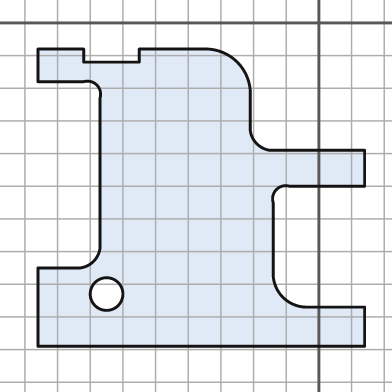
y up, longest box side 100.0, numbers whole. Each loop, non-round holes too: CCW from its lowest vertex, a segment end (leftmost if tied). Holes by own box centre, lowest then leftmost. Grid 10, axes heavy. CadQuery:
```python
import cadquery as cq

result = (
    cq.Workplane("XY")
    .moveTo(-86.0, -99.0)
    .lineTo(14.0, -99.0)
    .lineTo(14.0, -87.0)
    .lineTo(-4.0, -87.0)
    .threePointArc((-11.0, -84.0), (-14.0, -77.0))
    .lineTo(-14.0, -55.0)
    .threePointArc((-13.0, -51.0), (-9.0, -50.0))
    .lineTo(14.0, -50.0)
    .lineTo(14.0, -39.0)
    .lineTo(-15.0, -39.0)
    .threePointArc((-19.0, -37.0), (-21.0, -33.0))
    .lineTo(-21.0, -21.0)
    .threePointArc((-25.0, -12.0), (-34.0, -8.0))
    .lineTo(-55.0, -8.0)
    .lineTo(-55.0, -12.0)
    .lineTo(-72.0, -12.0)
    .lineTo(-72.0, -8.0)
    .lineTo(-86.0, -8.0)
    .lineTo(-86.0, -18.0)
    .lineTo(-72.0, -18.0)
    .threePointArc((-68.0, -19.0), (-67.0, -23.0))
    .lineTo(-67.0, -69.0)
    .threePointArc((-69.0, -73.0), (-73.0, -75.0))
    .lineTo(-86.0, -75.0)
    .close()
    .moveTo(-65.0, -83.0)
    .circle(5.0)
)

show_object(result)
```